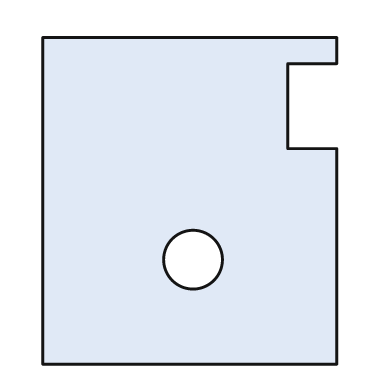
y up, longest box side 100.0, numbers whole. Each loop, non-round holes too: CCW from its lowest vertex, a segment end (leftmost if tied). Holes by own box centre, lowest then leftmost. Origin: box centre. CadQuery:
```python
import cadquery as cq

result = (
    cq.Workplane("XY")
    .moveTo(-45.0, -50.0)
    .lineTo(45.0, -50.0)
    .lineTo(45.0, 16.0)
    .lineTo(30.0, 16.0)
    .lineTo(30.0, 42.0)
    .lineTo(45.0, 42.0)
    .lineTo(45.0, 50.0)
    .lineTo(-45.0, 50.0)
    .close()
    .moveTo(1.0, -18.0)
    .circle(9.0)
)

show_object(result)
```